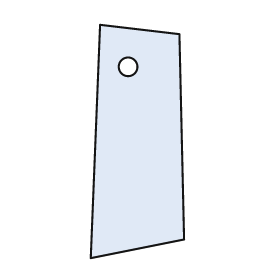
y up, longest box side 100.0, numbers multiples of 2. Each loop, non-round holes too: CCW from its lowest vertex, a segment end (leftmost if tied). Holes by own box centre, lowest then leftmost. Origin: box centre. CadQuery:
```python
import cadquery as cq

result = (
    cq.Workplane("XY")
    .moveTo(-20.0, -50.0)
    .lineTo(20.0, -42.0)
    .lineTo(18.0, 46.0)
    .lineTo(-16.0, 50.0)
    .close()
    .moveTo(-4.0, 32.0)
    .circle(4.0)
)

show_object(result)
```